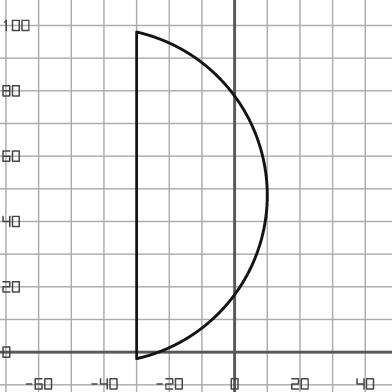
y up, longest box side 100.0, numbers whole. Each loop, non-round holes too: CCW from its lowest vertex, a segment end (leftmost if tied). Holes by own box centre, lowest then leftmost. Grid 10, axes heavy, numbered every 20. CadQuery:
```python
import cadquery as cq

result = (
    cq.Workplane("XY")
    .moveTo(-30.0, -2.0)
    .threePointArc((10.0, 48.0), (-30.0, 98.0))
    .close()
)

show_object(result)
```